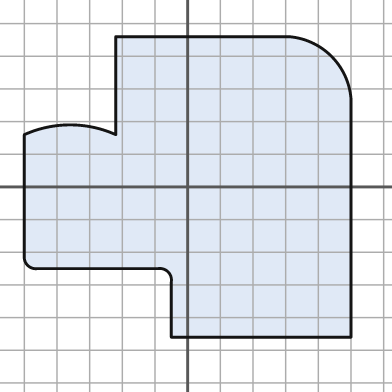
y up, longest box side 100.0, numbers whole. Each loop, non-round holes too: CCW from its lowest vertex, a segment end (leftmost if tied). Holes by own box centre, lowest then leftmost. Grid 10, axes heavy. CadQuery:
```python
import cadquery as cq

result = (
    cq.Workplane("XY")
    .moveTo(-5.0, -46.0)
    .lineTo(50.0, -46.0)
    .lineTo(50.0, 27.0)
    .threePointArc((44.0, 40.0), (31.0, 46.0))
    .lineTo(-22.0, 46.0)
    .lineTo(-22.0, 16.0)
    .threePointArc((-36.0, 19.0), (-50.0, 16.0))
    .lineTo(-50.0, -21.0)
    .threePointArc((-49.0, -24.0), (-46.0, -25.0))
    .lineTo(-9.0, -25.0)
    .threePointArc((-6.0, -26.0), (-5.0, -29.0))
    .close()
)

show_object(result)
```